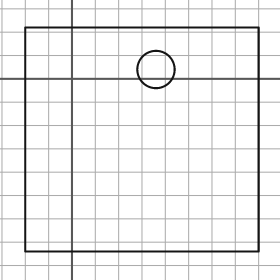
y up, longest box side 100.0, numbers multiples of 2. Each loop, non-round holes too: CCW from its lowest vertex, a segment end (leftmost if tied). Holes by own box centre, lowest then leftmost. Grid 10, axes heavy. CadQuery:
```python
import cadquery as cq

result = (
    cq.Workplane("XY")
    .moveTo(-20.0, -74.0)
    .lineTo(80.0, -74.0)
    .lineTo(80.0, 22.0)
    .lineTo(-20.0, 22.0)
    .close()
    .moveTo(36.0, 4.0)
    .circle(8.0)
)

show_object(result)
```